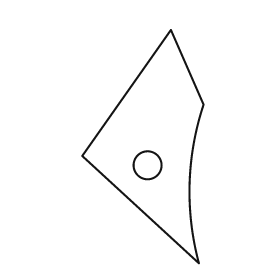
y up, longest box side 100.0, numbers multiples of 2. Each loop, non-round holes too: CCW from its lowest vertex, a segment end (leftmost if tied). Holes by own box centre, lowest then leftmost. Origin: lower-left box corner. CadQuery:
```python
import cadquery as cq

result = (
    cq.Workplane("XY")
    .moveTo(50.0, 0.0)
    .threePointArc((46.0, 34.0), (52.0, 68.0))
    .lineTo(38.0, 100.0)
    .lineTo(0.0, 46.0)
    .close()
    .moveTo(28.0, 42.0)
    .circle(6.0)
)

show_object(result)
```